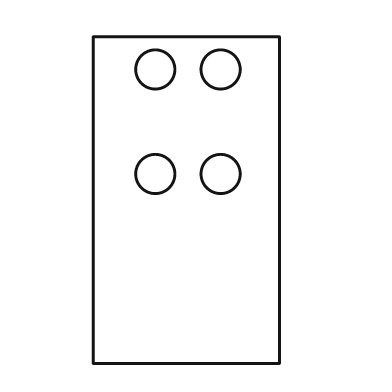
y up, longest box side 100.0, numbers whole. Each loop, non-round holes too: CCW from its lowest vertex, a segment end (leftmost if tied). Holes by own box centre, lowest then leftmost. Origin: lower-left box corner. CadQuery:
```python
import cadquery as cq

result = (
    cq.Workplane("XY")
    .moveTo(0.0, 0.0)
    .lineTo(57.0, 0.0)
    .lineTo(57.0, 100.0)
    .lineTo(0.0, 100.0)
    .close()
    .moveTo(19.0, 58.0)
    .circle(6.0)
    .moveTo(39.0, 58.0)
    .circle(6.0)
    .moveTo(19.0, 90.0)
    .circle(6.0)
    .moveTo(39.0, 90.0)
    .circle(6.0)
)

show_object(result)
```